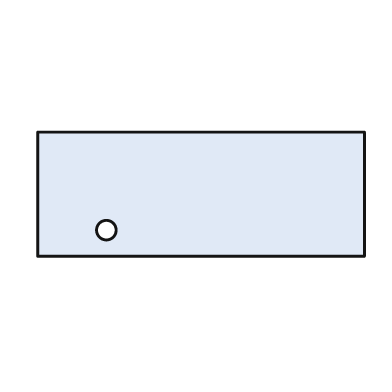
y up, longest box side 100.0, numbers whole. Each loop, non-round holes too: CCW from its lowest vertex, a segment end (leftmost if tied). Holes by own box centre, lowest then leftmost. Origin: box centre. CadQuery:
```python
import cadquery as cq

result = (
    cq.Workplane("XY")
    .moveTo(-50.0, -19.0)
    .lineTo(50.0, -19.0)
    .lineTo(50.0, 19.0)
    .lineTo(-50.0, 19.0)
    .close()
    .moveTo(-29.0, -11.0)
    .circle(3.0)
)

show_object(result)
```